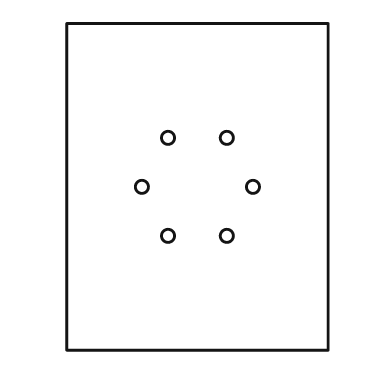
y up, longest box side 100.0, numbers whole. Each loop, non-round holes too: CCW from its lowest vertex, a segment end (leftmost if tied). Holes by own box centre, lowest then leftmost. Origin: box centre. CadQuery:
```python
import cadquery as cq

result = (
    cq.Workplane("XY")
    .moveTo(-40.0, -50.0)
    .lineTo(40.0, -50.0)
    .lineTo(40.0, 50.0)
    .lineTo(-40.0, 50.0)
    .close()
    .moveTo(-9.0, -15.0)
    .circle(2.0)
    .moveTo(9.0, -15.0)
    .circle(2.0)
    .moveTo(-17.0, 0.0)
    .circle(2.0)
    .moveTo(17.0, 0.0)
    .circle(2.0)
    .moveTo(-9.0, 15.0)
    .circle(2.0)
    .moveTo(9.0, 15.0)
    .circle(2.0)
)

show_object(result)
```